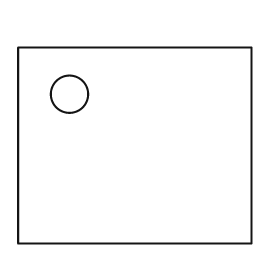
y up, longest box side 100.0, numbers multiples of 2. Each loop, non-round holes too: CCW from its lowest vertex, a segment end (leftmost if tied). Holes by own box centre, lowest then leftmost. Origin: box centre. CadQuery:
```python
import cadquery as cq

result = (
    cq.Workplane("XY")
    .moveTo(-50.0, -42.0)
    .lineTo(50.0, -42.0)
    .lineTo(50.0, 42.0)
    .lineTo(-50.0, 42.0)
    .close()
    .moveTo(-28.0, 22.0)
    .circle(8.0)
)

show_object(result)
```